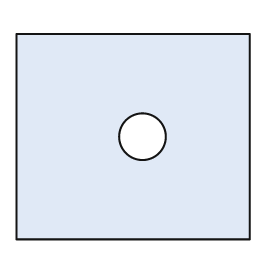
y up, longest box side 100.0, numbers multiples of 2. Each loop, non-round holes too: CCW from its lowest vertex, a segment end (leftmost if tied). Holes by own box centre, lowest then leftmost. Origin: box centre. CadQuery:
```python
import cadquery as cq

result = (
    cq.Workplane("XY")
    .moveTo(-50.0, -44.0)
    .lineTo(50.0, -44.0)
    .lineTo(50.0, 44.0)
    .lineTo(-50.0, 44.0)
    .close()
    .moveTo(4.0, 0.0)
    .circle(10.0)
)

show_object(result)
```